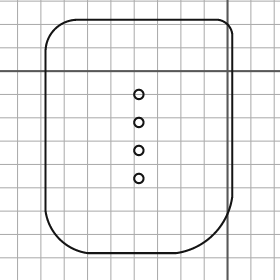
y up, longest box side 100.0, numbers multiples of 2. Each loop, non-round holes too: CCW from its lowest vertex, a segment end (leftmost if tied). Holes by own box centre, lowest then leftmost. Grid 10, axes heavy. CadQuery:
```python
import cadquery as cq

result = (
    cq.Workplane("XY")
    .moveTo(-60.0, -78.0)
    .lineTo(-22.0, -78.0)
    .threePointArc((-6.0, -70.0), (2.0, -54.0))
    .lineTo(2.0, 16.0)
    .threePointArc((0.0, 20.0), (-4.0, 22.0))
    .lineTo(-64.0, 22.0)
    .threePointArc((-74.0, 18.0), (-78.0, 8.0))
    .lineTo(-78.0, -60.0)
    .threePointArc((-72.0, -72.0), (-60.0, -78.0))
    .close()
    .moveTo(-38.0, -46.0)
    .circle(2.0)
    .moveTo(-38.0, -34.0)
    .circle(2.0)
    .moveTo(-38.0, -22.0)
    .circle(2.0)
    .moveTo(-38.0, -10.0)
    .circle(2.0)
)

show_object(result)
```